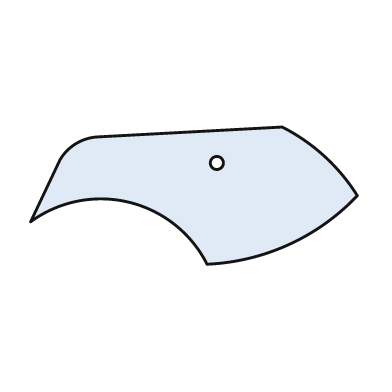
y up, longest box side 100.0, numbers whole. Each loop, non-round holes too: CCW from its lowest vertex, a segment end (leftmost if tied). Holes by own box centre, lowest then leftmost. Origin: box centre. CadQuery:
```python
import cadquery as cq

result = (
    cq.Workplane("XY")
    .moveTo(4.0, -21.0)
    .threePointArc((29.0, -15.0), (50.0, 0.0))
    .threePointArc((40.0, 12.0), (27.0, 21.0))
    .lineTo(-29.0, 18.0)
    .threePointArc((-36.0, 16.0), (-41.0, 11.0))
    .lineTo(-50.0, -8.0)
    .threePointArc((-20.0, -2.0), (4.0, -21.0))
    .close()
    .moveTo(7.0, 10.0)
    .circle(2.0)
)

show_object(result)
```